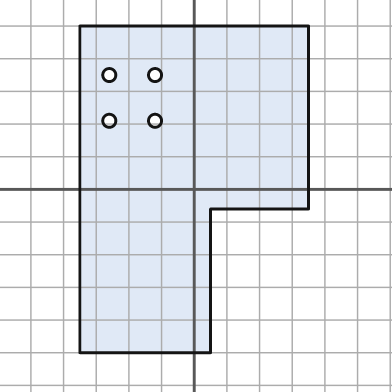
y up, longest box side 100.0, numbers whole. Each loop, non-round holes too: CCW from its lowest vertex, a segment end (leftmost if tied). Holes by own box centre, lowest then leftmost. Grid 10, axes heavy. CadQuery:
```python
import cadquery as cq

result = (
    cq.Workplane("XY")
    .moveTo(-35.0, -50.0)
    .lineTo(5.0, -50.0)
    .lineTo(5.0, -6.0)
    .lineTo(35.0, -6.0)
    .lineTo(35.0, 50.0)
    .lineTo(-35.0, 50.0)
    .close()
    .moveTo(-26.0, 21.0)
    .circle(2.0)
    .moveTo(-12.0, 21.0)
    .circle(2.0)
    .moveTo(-26.0, 35.0)
    .circle(2.0)
    .moveTo(-12.0, 35.0)
    .circle(2.0)
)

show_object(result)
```